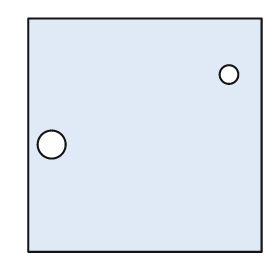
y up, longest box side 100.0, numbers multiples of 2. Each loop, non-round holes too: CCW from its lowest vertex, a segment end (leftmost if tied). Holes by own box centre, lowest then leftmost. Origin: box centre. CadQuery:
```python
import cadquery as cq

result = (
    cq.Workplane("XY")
    .moveTo(-50.0, -50.0)
    .lineTo(50.0, -50.0)
    .lineTo(50.0, 50.0)
    .lineTo(-50.0, 50.0)
    .close()
    .moveTo(-40.0, -4.0)
    .circle(6.0)
    .moveTo(36.0, 26.0)
    .circle(4.0)
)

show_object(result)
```